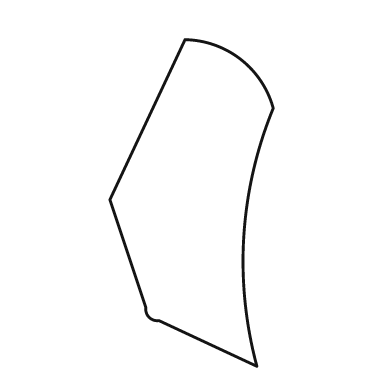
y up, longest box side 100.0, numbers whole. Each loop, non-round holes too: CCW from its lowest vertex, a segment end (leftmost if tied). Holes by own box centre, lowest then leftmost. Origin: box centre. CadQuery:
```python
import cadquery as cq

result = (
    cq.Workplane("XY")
    .moveTo(20.0, -50.0)
    .threePointArc((16.0, -10.0), (25.0, 29.0))
    .threePointArc((15.0, 44.0), (-2.0, 50.0))
    .lineTo(-25.0, 1.0)
    .lineTo(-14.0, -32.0)
    .threePointArc((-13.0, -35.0), (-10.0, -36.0))
    .close()
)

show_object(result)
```